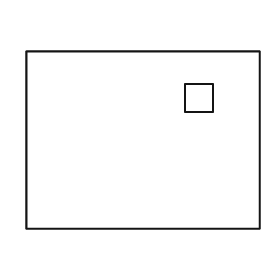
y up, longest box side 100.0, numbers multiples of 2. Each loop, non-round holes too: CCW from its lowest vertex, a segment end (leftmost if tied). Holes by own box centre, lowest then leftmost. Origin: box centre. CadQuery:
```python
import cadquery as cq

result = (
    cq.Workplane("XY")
    .moveTo(-50.0, -38.0)
    .lineTo(50.0, -38.0)
    .lineTo(50.0, 38.0)
    .lineTo(-50.0, 38.0)
    .close()
    .moveTo(18.0, 12.0)
    .lineTo(30.0, 12.0)
    .lineTo(30.0, 24.0)
    .lineTo(18.0, 24.0)
    .close()
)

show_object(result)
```